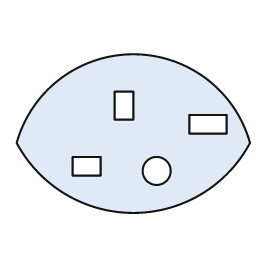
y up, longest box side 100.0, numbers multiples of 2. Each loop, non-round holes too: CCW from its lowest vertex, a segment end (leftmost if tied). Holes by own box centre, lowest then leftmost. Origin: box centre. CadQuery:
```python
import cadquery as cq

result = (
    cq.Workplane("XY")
    .moveTo(-50.0, -4.0)
    .threePointArc((0.0, -34.0), (50.0, -4.0))
    .threePointArc((0.0, 34.0), (-50.0, -4.0))
    .close()
    .moveTo(10.0, -16.0)
    .circle(6.0)
    .moveTo(-26.0, -18.0)
    .lineTo(-14.0, -18.0)
    .lineTo(-14.0, -10.0)
    .lineTo(-26.0, -10.0)
    .close()
    .moveTo(24.0, 0.0)
    .lineTo(40.0, 0.0)
    .lineTo(40.0, 8.0)
    .lineTo(24.0, 8.0)
    .close()
    .moveTo(-8.0, 6.0)
    .lineTo(0.0, 6.0)
    .lineTo(0.0, 18.0)
    .lineTo(-8.0, 18.0)
    .close()
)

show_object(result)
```